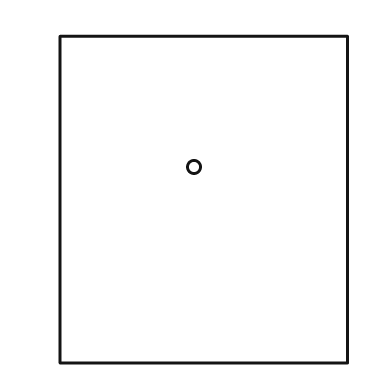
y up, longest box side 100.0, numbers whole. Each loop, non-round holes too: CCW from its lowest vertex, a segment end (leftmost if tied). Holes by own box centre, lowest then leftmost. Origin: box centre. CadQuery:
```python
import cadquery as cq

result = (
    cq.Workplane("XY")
    .moveTo(-44.0, -50.0)
    .lineTo(44.0, -50.0)
    .lineTo(44.0, 50.0)
    .lineTo(-44.0, 50.0)
    .close()
    .moveTo(-3.0, 10.0)
    .circle(2.0)
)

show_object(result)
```